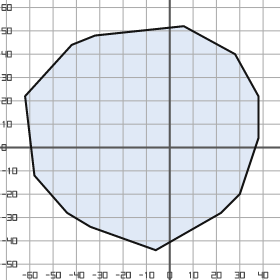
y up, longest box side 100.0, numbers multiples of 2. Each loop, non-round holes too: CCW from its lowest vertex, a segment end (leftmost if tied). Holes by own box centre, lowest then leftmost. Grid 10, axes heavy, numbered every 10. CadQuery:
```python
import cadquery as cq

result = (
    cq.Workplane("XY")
    .moveTo(-6.0, -44.0)
    .lineTo(22.0, -28.0)
    .lineTo(30.0, -20.0)
    .lineTo(38.0, 4.0)
    .lineTo(38.0, 22.0)
    .lineTo(28.0, 40.0)
    .lineTo(6.0, 52.0)
    .lineTo(-32.0, 48.0)
    .lineTo(-42.0, 44.0)
    .lineTo(-62.0, 22.0)
    .lineTo(-58.0, -12.0)
    .lineTo(-44.0, -28.0)
    .lineTo(-34.0, -34.0)
    .close()
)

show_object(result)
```